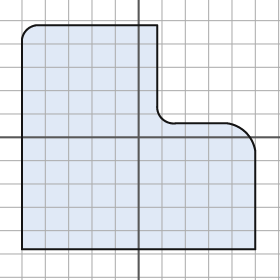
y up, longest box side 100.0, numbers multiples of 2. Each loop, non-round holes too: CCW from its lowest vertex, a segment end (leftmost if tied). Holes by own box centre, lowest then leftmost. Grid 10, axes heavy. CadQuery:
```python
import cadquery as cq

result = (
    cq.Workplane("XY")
    .moveTo(-50.0, -48.0)
    .lineTo(50.0, -48.0)
    .lineTo(50.0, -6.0)
    .threePointArc((46.0, 2.0), (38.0, 6.0))
    .lineTo(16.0, 6.0)
    .threePointArc((10.0, 8.0), (8.0, 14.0))
    .lineTo(8.0, 48.0)
    .lineTo(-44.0, 48.0)
    .threePointArc((-48.0, 46.0), (-50.0, 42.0))
    .close()
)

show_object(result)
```